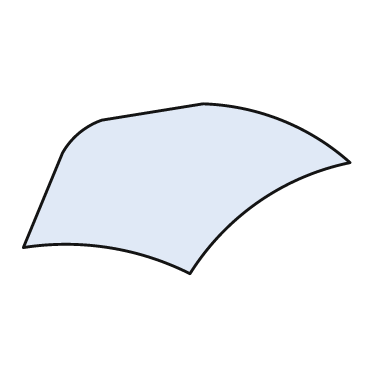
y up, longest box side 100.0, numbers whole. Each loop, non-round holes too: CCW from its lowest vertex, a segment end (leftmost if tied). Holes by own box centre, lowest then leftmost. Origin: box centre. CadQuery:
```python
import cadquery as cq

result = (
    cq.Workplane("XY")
    .moveTo(1.0, -26.0)
    .threePointArc((22.0, -4.0), (50.0, 8.0))
    .threePointArc((29.0, 21.0), (5.0, 26.0))
    .lineTo(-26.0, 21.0)
    .threePointArc((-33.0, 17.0), (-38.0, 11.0))
    .lineTo(-50.0, -18.0)
    .threePointArc((-24.0, -18.0), (1.0, -26.0))
    .close()
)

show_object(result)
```